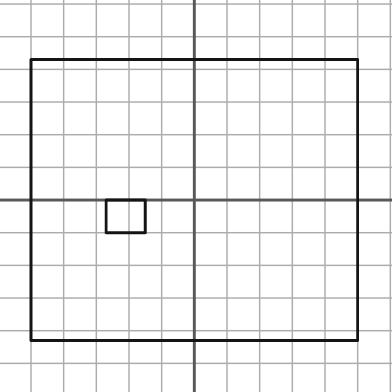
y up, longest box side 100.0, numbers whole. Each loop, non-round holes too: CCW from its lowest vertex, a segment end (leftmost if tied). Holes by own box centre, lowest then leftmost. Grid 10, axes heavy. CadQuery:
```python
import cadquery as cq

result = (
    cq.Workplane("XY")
    .moveTo(-50.0, -43.0)
    .lineTo(50.0, -43.0)
    .lineTo(50.0, 43.0)
    .lineTo(-50.0, 43.0)
    .close()
    .moveTo(-27.0, -10.0)
    .lineTo(-15.0, -10.0)
    .lineTo(-15.0, 0.0)
    .lineTo(-27.0, 0.0)
    .close()
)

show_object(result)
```